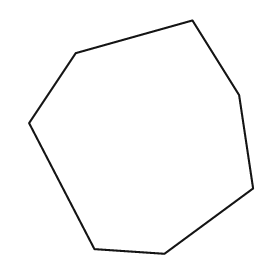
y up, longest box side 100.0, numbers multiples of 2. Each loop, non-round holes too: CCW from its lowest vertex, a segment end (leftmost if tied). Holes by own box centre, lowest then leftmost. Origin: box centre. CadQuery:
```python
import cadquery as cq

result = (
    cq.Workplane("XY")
    .moveTo(10.0, -50.0)
    .lineTo(48.0, -22.0)
    .lineTo(42.0, 18.0)
    .lineTo(22.0, 50.0)
    .lineTo(-28.0, 36.0)
    .lineTo(-48.0, 6.0)
    .lineTo(-20.0, -48.0)
    .close()
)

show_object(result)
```